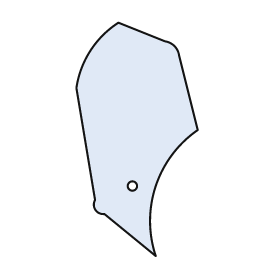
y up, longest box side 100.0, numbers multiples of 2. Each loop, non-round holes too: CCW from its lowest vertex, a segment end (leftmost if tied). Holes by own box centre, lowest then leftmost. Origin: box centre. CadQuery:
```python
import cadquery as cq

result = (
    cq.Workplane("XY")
    .moveTo(8.0, -50.0)
    .threePointArc((8.0, -20.0), (26.0, 4.0))
    .lineTo(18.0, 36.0)
    .threePointArc((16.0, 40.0), (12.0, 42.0))
    .lineTo(-8.0, 50.0)
    .threePointArc((-20.0, 38.0), (-26.0, 22.0))
    .lineTo(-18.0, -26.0)
    .threePointArc((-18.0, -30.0), (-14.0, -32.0))
    .close()
    .moveTo(-2.0, -20.0)
    .circle(2.0)
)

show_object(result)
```